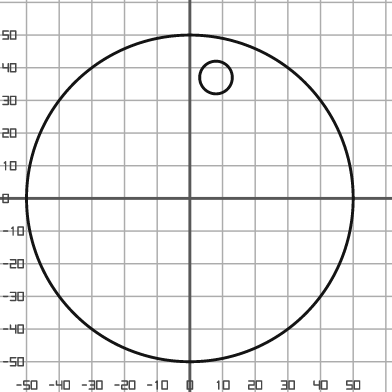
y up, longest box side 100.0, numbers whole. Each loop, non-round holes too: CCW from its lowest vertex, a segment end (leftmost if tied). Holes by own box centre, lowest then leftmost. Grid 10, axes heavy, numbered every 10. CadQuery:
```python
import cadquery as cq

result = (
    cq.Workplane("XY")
    .moveTo(0.0, 0.0)
    .circle(50.0)
    .moveTo(8.0, 37.0)
    .circle(5.0)
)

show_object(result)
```